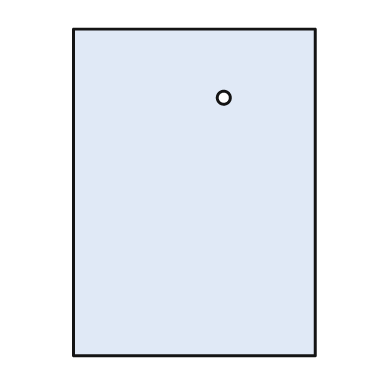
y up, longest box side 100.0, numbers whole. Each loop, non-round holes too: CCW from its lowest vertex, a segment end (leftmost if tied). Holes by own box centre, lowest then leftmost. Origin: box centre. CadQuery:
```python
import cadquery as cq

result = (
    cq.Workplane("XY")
    .moveTo(-37.0, -50.0)
    .lineTo(37.0, -50.0)
    .lineTo(37.0, 50.0)
    .lineTo(-37.0, 50.0)
    .close()
    .moveTo(9.0, 29.0)
    .circle(2.0)
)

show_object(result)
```